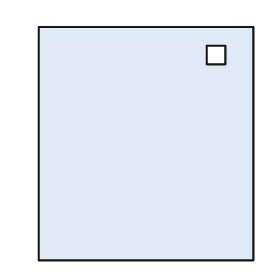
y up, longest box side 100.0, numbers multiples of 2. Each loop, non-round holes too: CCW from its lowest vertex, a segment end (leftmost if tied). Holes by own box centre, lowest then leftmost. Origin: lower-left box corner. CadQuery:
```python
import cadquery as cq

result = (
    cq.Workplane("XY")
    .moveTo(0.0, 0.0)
    .lineTo(92.0, 0.0)
    .lineTo(92.0, 100.0)
    .lineTo(0.0, 100.0)
    .close()
    .moveTo(72.0, 84.0)
    .lineTo(80.0, 84.0)
    .lineTo(80.0, 92.0)
    .lineTo(72.0, 92.0)
    .close()
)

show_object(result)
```